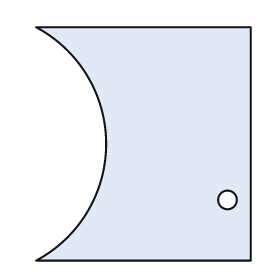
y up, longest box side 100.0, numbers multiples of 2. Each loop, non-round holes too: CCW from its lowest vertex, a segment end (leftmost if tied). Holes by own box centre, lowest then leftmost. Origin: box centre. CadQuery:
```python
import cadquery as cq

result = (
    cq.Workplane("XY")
    .moveTo(-46.0, -50.0)
    .lineTo(46.0, -50.0)
    .lineTo(46.0, 50.0)
    .lineTo(-46.0, 50.0)
    .threePointArc((-16.0, 0.0), (-46.0, -50.0))
    .close()
    .moveTo(36.0, -24.0)
    .circle(4.0)
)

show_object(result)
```